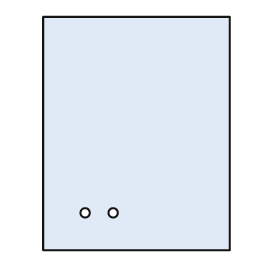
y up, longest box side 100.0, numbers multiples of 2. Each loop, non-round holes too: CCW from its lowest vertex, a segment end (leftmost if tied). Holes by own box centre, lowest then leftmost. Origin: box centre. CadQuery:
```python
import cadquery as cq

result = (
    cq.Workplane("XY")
    .moveTo(-40.0, -50.0)
    .lineTo(40.0, -50.0)
    .lineTo(40.0, 50.0)
    .lineTo(-40.0, 50.0)
    .close()
    .moveTo(-22.0, -34.0)
    .circle(2.0)
    .moveTo(-10.0, -34.0)
    .circle(2.0)
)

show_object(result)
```